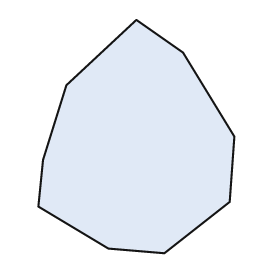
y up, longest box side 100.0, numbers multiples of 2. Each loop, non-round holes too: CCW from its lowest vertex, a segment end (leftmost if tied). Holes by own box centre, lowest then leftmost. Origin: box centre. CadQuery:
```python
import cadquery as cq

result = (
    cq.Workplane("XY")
    .moveTo(12.0, -50.0)
    .lineTo(40.0, -28.0)
    .lineTo(42.0, 0.0)
    .lineTo(20.0, 36.0)
    .lineTo(0.0, 50.0)
    .lineTo(-30.0, 22.0)
    .lineTo(-40.0, -10.0)
    .lineTo(-42.0, -30.0)
    .lineTo(-12.0, -48.0)
    .close()
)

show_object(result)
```